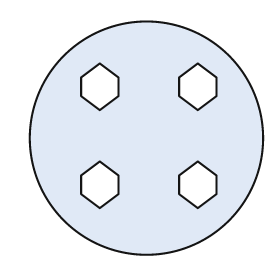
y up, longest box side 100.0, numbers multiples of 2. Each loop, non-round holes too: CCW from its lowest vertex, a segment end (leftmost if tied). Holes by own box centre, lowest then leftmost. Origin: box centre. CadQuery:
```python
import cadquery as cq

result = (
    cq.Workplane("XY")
    .moveTo(0.0, 0.0)
    .circle(50.0)
    .moveTo(-20.0, -30.0)
    .lineTo(-12.0, -24.0)
    .lineTo(-12.0, -16.0)
    .lineTo(-20.0, -10.0)
    .lineTo(-28.0, -16.0)
    .lineTo(-28.0, -24.0)
    .close()
    .moveTo(22.0, -30.0)
    .lineTo(30.0, -24.0)
    .lineTo(30.0, -16.0)
    .lineTo(22.0, -10.0)
    .lineTo(14.0, -16.0)
    .lineTo(14.0, -24.0)
    .close()
    .moveTo(-20.0, 12.0)
    .lineTo(-12.0, 18.0)
    .lineTo(-12.0, 26.0)
    .lineTo(-20.0, 32.0)
    .lineTo(-28.0, 26.0)
    .lineTo(-28.0, 18.0)
    .close()
    .moveTo(22.0, 12.0)
    .lineTo(30.0, 18.0)
    .lineTo(30.0, 26.0)
    .lineTo(22.0, 32.0)
    .lineTo(14.0, 26.0)
    .lineTo(14.0, 18.0)
    .close()
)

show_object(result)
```